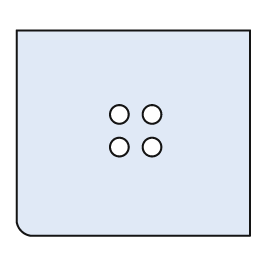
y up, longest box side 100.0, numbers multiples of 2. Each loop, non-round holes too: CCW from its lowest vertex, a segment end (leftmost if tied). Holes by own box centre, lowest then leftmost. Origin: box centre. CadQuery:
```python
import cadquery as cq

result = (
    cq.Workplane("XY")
    .moveTo(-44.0, -44.0)
    .lineTo(50.0, -44.0)
    .lineTo(50.0, 44.0)
    .lineTo(-50.0, 44.0)
    .lineTo(-50.0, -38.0)
    .threePointArc((-48.0, -42.0), (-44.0, -44.0))
    .close()
    .moveTo(-6.0, -6.0)
    .circle(4.0)
    .moveTo(8.0, -6.0)
    .circle(4.0)
    .moveTo(-6.0, 8.0)
    .circle(4.0)
    .moveTo(8.0, 8.0)
    .circle(4.0)
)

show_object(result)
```